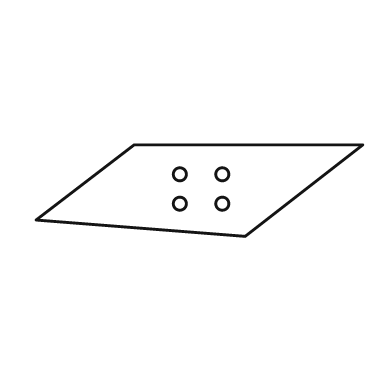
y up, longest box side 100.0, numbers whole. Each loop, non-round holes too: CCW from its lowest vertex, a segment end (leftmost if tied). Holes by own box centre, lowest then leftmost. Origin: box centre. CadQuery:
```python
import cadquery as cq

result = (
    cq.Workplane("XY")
    .moveTo(14.0, -14.0)
    .lineTo(50.0, 14.0)
    .lineTo(-20.0, 14.0)
    .lineTo(-50.0, -9.0)
    .close()
    .moveTo(-6.0, -4.0)
    .circle(2.0)
    .moveTo(7.0, -4.0)
    .circle(2.0)
    .moveTo(-6.0, 5.0)
    .circle(2.0)
    .moveTo(7.0, 5.0)
    .circle(2.0)
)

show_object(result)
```